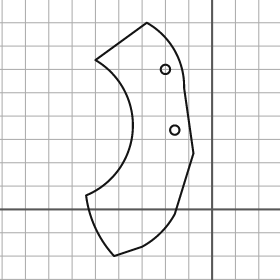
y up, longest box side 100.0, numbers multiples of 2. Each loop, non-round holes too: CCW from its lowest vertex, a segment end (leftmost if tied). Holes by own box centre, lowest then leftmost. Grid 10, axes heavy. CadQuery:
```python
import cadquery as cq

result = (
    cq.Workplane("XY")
    .moveTo(-42.0, -20.0)
    .lineTo(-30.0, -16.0)
    .threePointArc((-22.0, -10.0), (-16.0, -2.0))
    .lineTo(-8.0, 24.0)
    .lineTo(-12.0, 52.0)
    .threePointArc((-16.0, 68.0), (-28.0, 80.0))
    .lineTo(-50.0, 64.0)
    .threePointArc((-34.0, 34.0), (-54.0, 6.0))
    .threePointArc((-50.0, -8.0), (-42.0, -20.0))
    .close()
    .moveTo(-16.0, 34.0)
    .circle(2.0)
    .moveTo(-20.0, 60.0)
    .circle(2.0)
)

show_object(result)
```